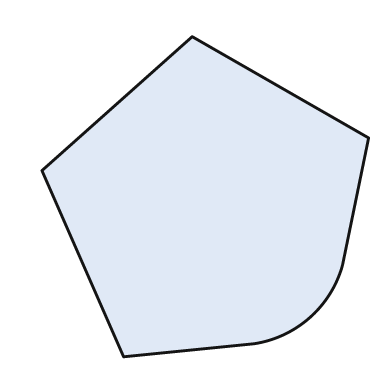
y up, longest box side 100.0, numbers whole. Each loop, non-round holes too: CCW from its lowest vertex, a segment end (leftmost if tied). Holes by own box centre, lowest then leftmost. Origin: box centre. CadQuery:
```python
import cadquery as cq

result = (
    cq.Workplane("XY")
    .moveTo(-25.0, -49.0)
    .lineTo(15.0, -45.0)
    .threePointArc((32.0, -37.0), (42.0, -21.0))
    .lineTo(50.0, 18.0)
    .lineTo(-4.0, 49.0)
    .lineTo(-50.0, 8.0)
    .close()
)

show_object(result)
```